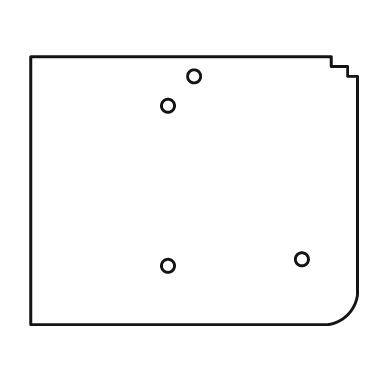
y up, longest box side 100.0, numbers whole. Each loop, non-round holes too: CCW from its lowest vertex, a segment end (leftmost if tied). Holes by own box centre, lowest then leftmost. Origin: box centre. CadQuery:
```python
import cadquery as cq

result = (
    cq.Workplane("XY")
    .moveTo(-50.0, -41.0)
    .lineTo(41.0, -41.0)
    .threePointArc((47.0, -38.0), (50.0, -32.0))
    .lineTo(50.0, 35.0)
    .lineTo(47.0, 35.0)
    .lineTo(47.0, 38.0)
    .lineTo(42.0, 38.0)
    .lineTo(42.0, 41.0)
    .lineTo(-50.0, 41.0)
    .close()
    .moveTo(-8.0, -23.0)
    .circle(2.0)
    .moveTo(33.0, -21.0)
    .circle(2.0)
    .moveTo(-8.0, 26.0)
    .circle(2.0)
    .moveTo(0.0, 35.0)
    .circle(2.0)
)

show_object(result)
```